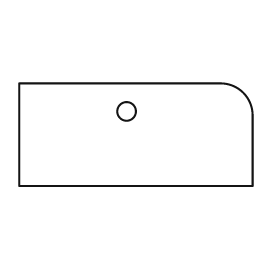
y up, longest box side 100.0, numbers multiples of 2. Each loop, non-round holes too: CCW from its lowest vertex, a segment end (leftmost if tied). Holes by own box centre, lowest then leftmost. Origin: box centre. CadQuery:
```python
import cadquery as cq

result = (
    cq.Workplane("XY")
    .moveTo(-50.0, -22.0)
    .lineTo(50.0, -22.0)
    .lineTo(50.0, 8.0)
    .threePointArc((46.0, 18.0), (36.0, 22.0))
    .lineTo(-50.0, 22.0)
    .close()
    .moveTo(-4.0, 10.0)
    .circle(4.0)
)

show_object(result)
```